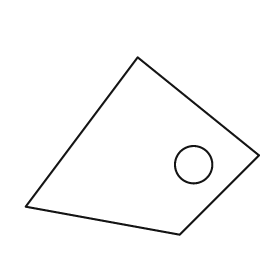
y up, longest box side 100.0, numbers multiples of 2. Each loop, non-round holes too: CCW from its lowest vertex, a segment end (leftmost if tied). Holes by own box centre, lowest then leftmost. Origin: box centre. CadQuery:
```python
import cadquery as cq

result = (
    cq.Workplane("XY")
    .moveTo(16.0, -38.0)
    .lineTo(50.0, -4.0)
    .lineTo(-2.0, 38.0)
    .lineTo(-50.0, -26.0)
    .close()
    .moveTo(22.0, -8.0)
    .circle(8.0)
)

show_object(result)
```